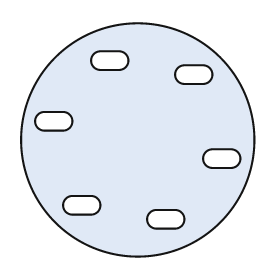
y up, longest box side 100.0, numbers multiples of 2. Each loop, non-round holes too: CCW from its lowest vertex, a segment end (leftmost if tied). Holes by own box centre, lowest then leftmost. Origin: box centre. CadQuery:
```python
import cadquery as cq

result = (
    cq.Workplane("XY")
    .moveTo(0.0, 0.0)
    .circle(50.0)
    .moveTo(8.0, -38.0)
    .lineTo(16.0, -38.0)
    .threePointArc((20.0, -34.0), (16.0, -30.0))
    .lineTo(8.0, -30.0)
    .threePointArc((4.0, -34.0), (8.0, -38.0))
    .close()
    .moveTo(-28.0, -32.0)
    .lineTo(-20.0, -32.0)
    .threePointArc((-16.0, -28.0), (-20.0, -24.0))
    .lineTo(-28.0, -24.0)
    .threePointArc((-32.0, -28.0), (-28.0, -32.0))
    .close()
    .moveTo(32.0, -12.0)
    .lineTo(40.0, -12.0)
    .threePointArc((44.0, -8.0), (40.0, -4.0))
    .lineTo(32.0, -4.0)
    .threePointArc((28.0, -8.0), (32.0, -12.0))
    .close()
    .moveTo(-40.0, 4.0)
    .lineTo(-32.0, 4.0)
    .threePointArc((-28.0, 8.0), (-32.0, 12.0))
    .lineTo(-40.0, 12.0)
    .threePointArc((-44.0, 8.0), (-40.0, 4.0))
    .close()
    .moveTo(20.0, 24.0)
    .lineTo(28.0, 24.0)
    .threePointArc((32.0, 28.0), (28.0, 32.0))
    .lineTo(20.0, 32.0)
    .threePointArc((16.0, 28.0), (20.0, 24.0))
    .close()
    .moveTo(-16.0, 30.0)
    .lineTo(-8.0, 30.0)
    .threePointArc((-4.0, 34.0), (-8.0, 38.0))
    .lineTo(-16.0, 38.0)
    .threePointArc((-20.0, 34.0), (-16.0, 30.0))
    .close()
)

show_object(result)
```